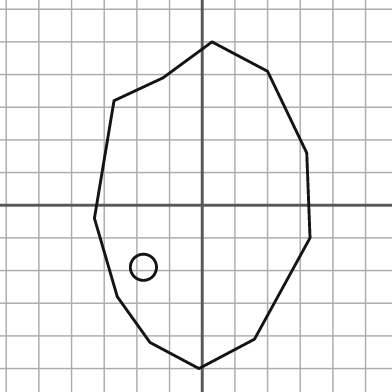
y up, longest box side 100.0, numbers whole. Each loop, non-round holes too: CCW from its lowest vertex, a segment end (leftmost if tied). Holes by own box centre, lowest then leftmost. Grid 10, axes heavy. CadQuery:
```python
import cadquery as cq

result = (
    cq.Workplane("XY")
    .moveTo(-1.0, -50.0)
    .lineTo(16.0, -41.0)
    .lineTo(33.0, -10.0)
    .lineTo(32.0, 16.0)
    .lineTo(20.0, 41.0)
    .lineTo(3.0, 50.0)
    .lineTo(-12.0, 39.0)
    .lineTo(-27.0, 32.0)
    .lineTo(-33.0, -4.0)
    .lineTo(-26.0, -28.0)
    .lineTo(-16.0, -42.0)
    .close()
    .moveTo(-18.0, -19.0)
    .circle(4.0)
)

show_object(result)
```